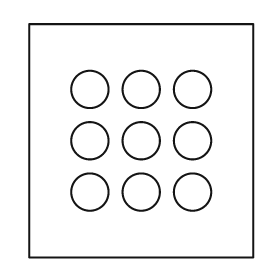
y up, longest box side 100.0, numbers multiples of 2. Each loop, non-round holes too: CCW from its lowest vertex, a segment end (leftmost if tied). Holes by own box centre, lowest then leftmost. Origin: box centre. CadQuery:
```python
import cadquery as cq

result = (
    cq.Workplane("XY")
    .moveTo(-48.0, -50.0)
    .lineTo(48.0, -50.0)
    .lineTo(48.0, 50.0)
    .lineTo(-48.0, 50.0)
    .close()
    .moveTo(-22.0, -22.0)
    .circle(8.0)
    .moveTo(0.0, -22.0)
    .circle(8.0)
    .moveTo(22.0, -22.0)
    .circle(8.0)
    .moveTo(-22.0, 0.0)
    .circle(8.0)
    .moveTo(0.0, 0.0)
    .circle(8.0)
    .moveTo(22.0, 0.0)
    .circle(8.0)
    .moveTo(-22.0, 22.0)
    .circle(8.0)
    .moveTo(0.0, 22.0)
    .circle(8.0)
    .moveTo(22.0, 22.0)
    .circle(8.0)
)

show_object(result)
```